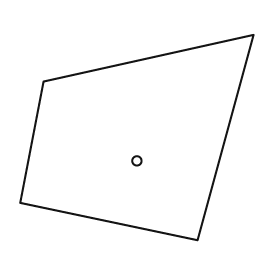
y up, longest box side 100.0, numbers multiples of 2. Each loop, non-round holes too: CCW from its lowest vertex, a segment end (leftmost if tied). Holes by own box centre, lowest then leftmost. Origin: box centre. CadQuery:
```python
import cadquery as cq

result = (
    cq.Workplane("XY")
    .moveTo(26.0, -44.0)
    .lineTo(50.0, 44.0)
    .lineTo(-40.0, 24.0)
    .lineTo(-50.0, -28.0)
    .close()
    .moveTo(0.0, -10.0)
    .circle(2.0)
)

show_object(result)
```